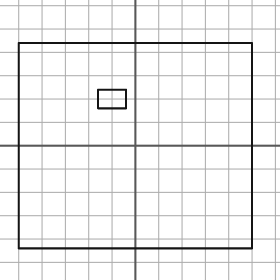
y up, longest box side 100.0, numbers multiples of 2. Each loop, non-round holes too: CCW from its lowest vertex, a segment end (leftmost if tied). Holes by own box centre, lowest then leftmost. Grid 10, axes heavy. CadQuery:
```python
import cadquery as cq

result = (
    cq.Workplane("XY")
    .moveTo(-50.0, -44.0)
    .lineTo(50.0, -44.0)
    .lineTo(50.0, 44.0)
    .lineTo(-50.0, 44.0)
    .close()
    .moveTo(-16.0, 16.0)
    .lineTo(-4.0, 16.0)
    .lineTo(-4.0, 24.0)
    .lineTo(-16.0, 24.0)
    .close()
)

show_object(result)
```